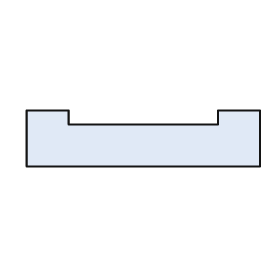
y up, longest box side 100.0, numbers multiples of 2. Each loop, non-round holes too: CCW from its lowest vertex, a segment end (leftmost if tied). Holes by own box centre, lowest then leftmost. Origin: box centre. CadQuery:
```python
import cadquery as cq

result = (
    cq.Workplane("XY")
    .moveTo(-50.0, -12.0)
    .lineTo(50.0, -12.0)
    .lineTo(50.0, 12.0)
    .lineTo(32.0, 12.0)
    .lineTo(32.0, 6.0)
    .lineTo(-32.0, 6.0)
    .lineTo(-32.0, 12.0)
    .lineTo(-50.0, 12.0)
    .close()
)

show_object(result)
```